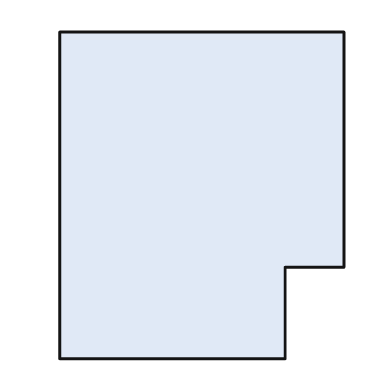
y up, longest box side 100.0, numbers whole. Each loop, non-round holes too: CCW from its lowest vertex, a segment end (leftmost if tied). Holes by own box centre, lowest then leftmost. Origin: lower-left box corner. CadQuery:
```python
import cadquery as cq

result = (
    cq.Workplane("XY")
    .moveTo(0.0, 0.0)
    .lineTo(69.0, 0.0)
    .lineTo(69.0, 28.0)
    .lineTo(87.0, 28.0)
    .lineTo(87.0, 100.0)
    .lineTo(0.0, 100.0)
    .close()
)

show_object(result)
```